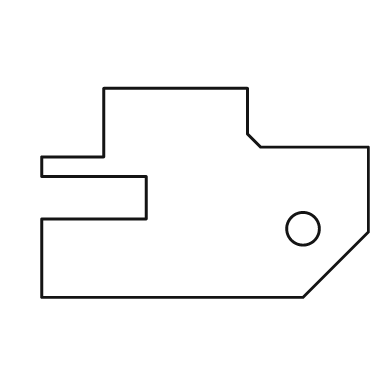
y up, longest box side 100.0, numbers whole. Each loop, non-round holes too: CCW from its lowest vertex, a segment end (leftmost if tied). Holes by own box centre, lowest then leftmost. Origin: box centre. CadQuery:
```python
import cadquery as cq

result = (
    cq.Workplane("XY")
    .moveTo(-50.0, -32.0)
    .lineTo(30.0, -32.0)
    .lineTo(50.0, -12.0)
    .lineTo(50.0, 14.0)
    .lineTo(17.0, 14.0)
    .lineTo(13.0, 18.0)
    .lineTo(13.0, 32.0)
    .lineTo(-31.0, 32.0)
    .lineTo(-31.0, 11.0)
    .lineTo(-50.0, 11.0)
    .lineTo(-50.0, 5.0)
    .lineTo(-18.0, 5.0)
    .lineTo(-18.0, -8.0)
    .lineTo(-50.0, -8.0)
    .close()
    .moveTo(30.0, -11.0)
    .circle(5.0)
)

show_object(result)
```